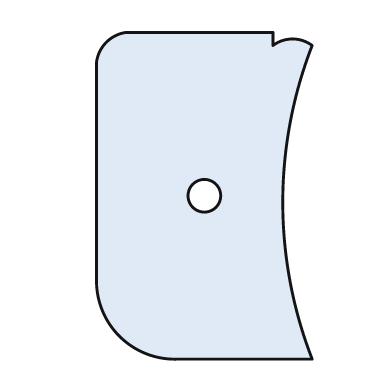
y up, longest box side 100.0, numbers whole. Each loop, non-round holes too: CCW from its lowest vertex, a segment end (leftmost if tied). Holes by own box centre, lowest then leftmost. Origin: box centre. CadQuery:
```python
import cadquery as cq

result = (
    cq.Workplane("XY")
    .moveTo(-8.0, -50.0)
    .lineTo(33.0, -50.0)
    .threePointArc((24.0, -2.0), (33.0, 46.0))
    .threePointArc((27.0, 48.0), (21.0, 46.0))
    .lineTo(21.0, 50.0)
    .lineTo(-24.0, 50.0)
    .threePointArc((-30.0, 47.0), (-33.0, 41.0))
    .lineTo(-33.0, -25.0)
    .threePointArc((-26.0, -43.0), (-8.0, -50.0))
    .close()
    .moveTo(0.0, 0.0)
    .circle(5.0)
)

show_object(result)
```